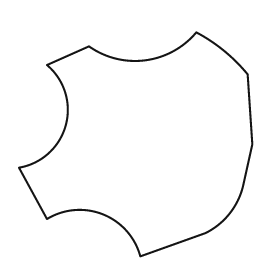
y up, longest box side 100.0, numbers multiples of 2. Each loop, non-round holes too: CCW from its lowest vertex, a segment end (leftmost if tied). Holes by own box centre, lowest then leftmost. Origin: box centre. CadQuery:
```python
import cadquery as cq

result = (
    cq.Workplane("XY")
    .moveTo(2.0, -48.0)
    .lineTo(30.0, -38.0)
    .threePointArc((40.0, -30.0), (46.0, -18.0))
    .lineTo(50.0, 0.0)
    .lineTo(48.0, 30.0)
    .threePointArc((38.0, 40.0), (26.0, 48.0))
    .threePointArc((4.0, 36.0), (-20.0, 42.0))
    .lineTo(-38.0, 34.0)
    .threePointArc((-30.0, 8.0), (-50.0, -10.0))
    .lineTo(-38.0, -32.0)
    .threePointArc((-14.0, -30.0), (2.0, -48.0))
    .close()
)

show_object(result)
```